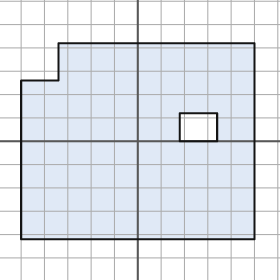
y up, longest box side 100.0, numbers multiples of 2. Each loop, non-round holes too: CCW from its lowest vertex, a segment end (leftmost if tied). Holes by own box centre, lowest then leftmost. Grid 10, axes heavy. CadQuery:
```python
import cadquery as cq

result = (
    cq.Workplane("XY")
    .moveTo(-50.0, -42.0)
    .lineTo(50.0, -42.0)
    .lineTo(50.0, 42.0)
    .lineTo(-34.0, 42.0)
    .lineTo(-34.0, 26.0)
    .lineTo(-50.0, 26.0)
    .close()
    .moveTo(18.0, 0.0)
    .lineTo(34.0, 0.0)
    .lineTo(34.0, 12.0)
    .lineTo(18.0, 12.0)
    .close()
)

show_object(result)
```